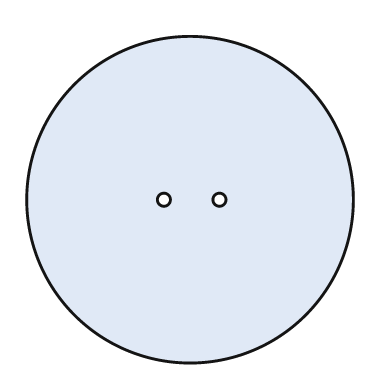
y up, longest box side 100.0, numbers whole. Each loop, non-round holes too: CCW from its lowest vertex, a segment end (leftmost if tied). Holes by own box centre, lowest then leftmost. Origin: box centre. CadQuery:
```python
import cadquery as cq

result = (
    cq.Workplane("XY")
    .moveTo(0.0, 0.0)
    .circle(50.0)
    .moveTo(-8.0, 0.0)
    .circle(2.0)
    .moveTo(9.0, 0.0)
    .circle(2.0)
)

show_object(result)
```